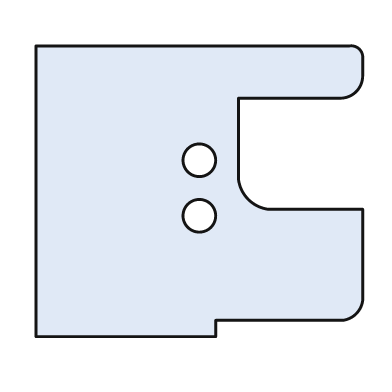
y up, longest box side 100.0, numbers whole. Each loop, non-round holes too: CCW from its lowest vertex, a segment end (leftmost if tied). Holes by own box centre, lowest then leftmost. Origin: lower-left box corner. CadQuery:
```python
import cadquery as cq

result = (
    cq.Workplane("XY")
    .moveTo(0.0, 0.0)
    .lineTo(55.0, 0.0)
    .lineTo(55.0, 5.0)
    .lineTo(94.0, 5.0)
    .threePointArc((98.0, 7.0), (100.0, 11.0))
    .lineTo(100.0, 39.0)
    .lineTo(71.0, 39.0)
    .threePointArc((65.0, 42.0), (62.0, 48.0))
    .lineTo(62.0, 73.0)
    .lineTo(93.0, 73.0)
    .threePointArc((98.0, 75.0), (100.0, 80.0))
    .lineTo(100.0, 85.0)
    .threePointArc((99.0, 88.0), (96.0, 89.0))
    .lineTo(0.0, 89.0)
    .close()
    .moveTo(50.0, 37.0)
    .circle(5.0)
    .moveTo(50.0, 54.0)
    .circle(5.0)
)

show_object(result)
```